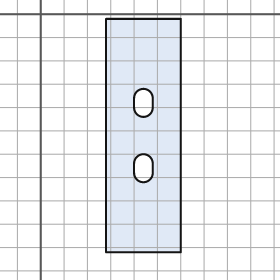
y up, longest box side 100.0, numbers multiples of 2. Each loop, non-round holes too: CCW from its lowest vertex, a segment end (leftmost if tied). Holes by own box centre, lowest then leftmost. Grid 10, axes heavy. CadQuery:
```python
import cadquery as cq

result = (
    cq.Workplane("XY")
    .moveTo(28.0, -102.0)
    .lineTo(60.0, -102.0)
    .lineTo(60.0, -2.0)
    .lineTo(28.0, -2.0)
    .close()
    .moveTo(40.0, -68.0)
    .threePointArc((44.0, -72.0), (48.0, -68.0))
    .lineTo(48.0, -64.0)
    .threePointArc((44.0, -60.0), (40.0, -64.0))
    .close()
    .moveTo(40.0, -40.0)
    .threePointArc((44.0, -44.0), (48.0, -40.0))
    .lineTo(48.0, -36.0)
    .threePointArc((44.0, -32.0), (40.0, -36.0))
    .close()
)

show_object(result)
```